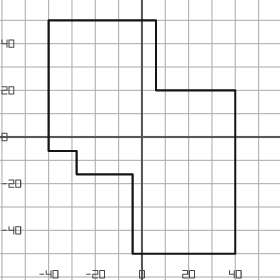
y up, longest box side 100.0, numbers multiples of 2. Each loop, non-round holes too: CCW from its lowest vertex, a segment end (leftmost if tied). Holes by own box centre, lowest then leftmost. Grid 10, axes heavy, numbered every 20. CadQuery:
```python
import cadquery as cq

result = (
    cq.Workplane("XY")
    .moveTo(-4.0, -50.0)
    .lineTo(40.0, -50.0)
    .lineTo(40.0, 20.0)
    .lineTo(6.0, 20.0)
    .lineTo(6.0, 50.0)
    .lineTo(-40.0, 50.0)
    .lineTo(-40.0, -6.0)
    .lineTo(-28.0, -6.0)
    .lineTo(-28.0, -16.0)
    .lineTo(-4.0, -16.0)
    .close()
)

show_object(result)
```